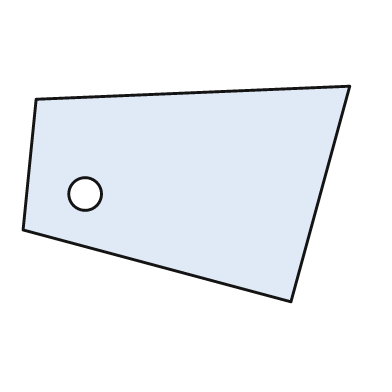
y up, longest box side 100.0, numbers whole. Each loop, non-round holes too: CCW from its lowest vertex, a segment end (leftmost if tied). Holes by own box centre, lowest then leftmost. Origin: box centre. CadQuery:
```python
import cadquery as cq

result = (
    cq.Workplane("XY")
    .moveTo(32.0, -33.0)
    .lineTo(50.0, 33.0)
    .lineTo(-46.0, 29.0)
    .lineTo(-50.0, -11.0)
    .close()
    .moveTo(-31.0, 0.0)
    .circle(5.0)
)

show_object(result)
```